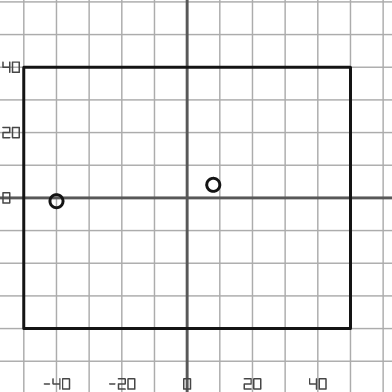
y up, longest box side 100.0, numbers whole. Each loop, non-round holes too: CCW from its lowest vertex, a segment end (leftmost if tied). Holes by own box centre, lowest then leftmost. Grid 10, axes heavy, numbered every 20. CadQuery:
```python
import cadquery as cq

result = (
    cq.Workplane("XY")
    .moveTo(-50.0, -40.0)
    .lineTo(50.0, -40.0)
    .lineTo(50.0, 40.0)
    .lineTo(-50.0, 40.0)
    .close()
    .moveTo(-40.0, -1.0)
    .circle(2.0)
    .moveTo(8.0, 4.0)
    .circle(2.0)
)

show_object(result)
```